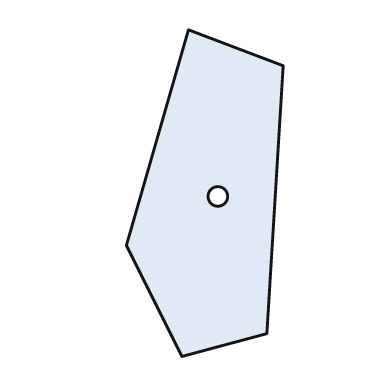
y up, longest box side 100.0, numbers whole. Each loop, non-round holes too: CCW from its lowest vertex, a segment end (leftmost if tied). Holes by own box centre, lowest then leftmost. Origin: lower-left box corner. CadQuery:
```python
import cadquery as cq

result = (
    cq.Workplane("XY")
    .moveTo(17.0, 0.0)
    .lineTo(43.0, 7.0)
    .lineTo(48.0, 89.0)
    .lineTo(19.0, 100.0)
    .lineTo(0.0, 34.0)
    .close()
    .moveTo(28.0, 49.0)
    .circle(3.0)
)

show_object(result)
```